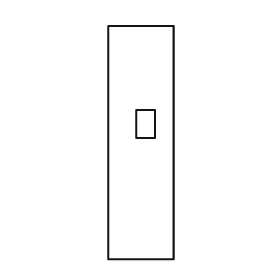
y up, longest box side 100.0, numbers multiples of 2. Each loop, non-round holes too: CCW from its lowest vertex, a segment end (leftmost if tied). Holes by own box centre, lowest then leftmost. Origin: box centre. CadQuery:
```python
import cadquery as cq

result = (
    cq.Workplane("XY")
    .moveTo(-14.0, -50.0)
    .lineTo(14.0, -50.0)
    .lineTo(14.0, 50.0)
    .lineTo(-14.0, 50.0)
    .close()
    .moveTo(-2.0, 2.0)
    .lineTo(6.0, 2.0)
    .lineTo(6.0, 14.0)
    .lineTo(-2.0, 14.0)
    .close()
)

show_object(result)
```